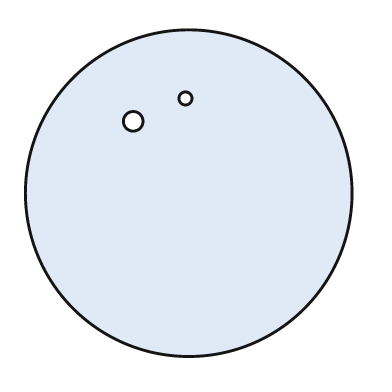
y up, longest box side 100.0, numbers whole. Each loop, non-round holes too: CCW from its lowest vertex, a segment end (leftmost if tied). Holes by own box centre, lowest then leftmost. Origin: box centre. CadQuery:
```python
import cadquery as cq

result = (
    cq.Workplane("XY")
    .moveTo(0.0, 0.0)
    .circle(50.0)
    .moveTo(-17.0, 22.0)
    .circle(3.0)
    .moveTo(-1.0, 29.0)
    .circle(2.0)
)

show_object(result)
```